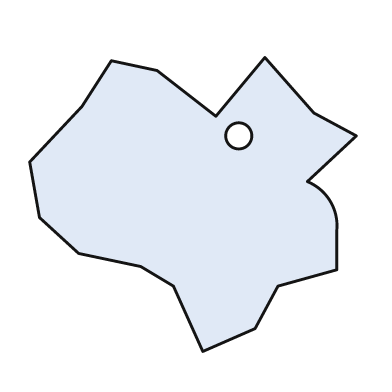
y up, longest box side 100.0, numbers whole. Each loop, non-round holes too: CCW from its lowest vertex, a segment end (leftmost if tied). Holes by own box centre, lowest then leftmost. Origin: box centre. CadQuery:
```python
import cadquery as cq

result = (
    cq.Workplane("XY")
    .moveTo(3.0, -45.0)
    .lineTo(19.0, -38.0)
    .lineTo(26.0, -25.0)
    .lineTo(44.0, -20.0)
    .lineTo(44.0, -8.0)
    .threePointArc((42.0, 1.0), (35.0, 7.0))
    .lineTo(50.0, 21.0)
    .lineTo(37.0, 28.0)
    .lineTo(22.0, 45.0)
    .lineTo(7.0, 27.0)
    .lineTo(-11.0, 41.0)
    .lineTo(-25.0, 44.0)
    .lineTo(-34.0, 30.0)
    .lineTo(-50.0, 13.0)
    .lineTo(-47.0, -4.0)
    .lineTo(-35.0, -15.0)
    .lineTo(-16.0, -19.0)
    .lineTo(-6.0, -25.0)
    .close()
    .moveTo(14.0, 21.0)
    .circle(4.0)
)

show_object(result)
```